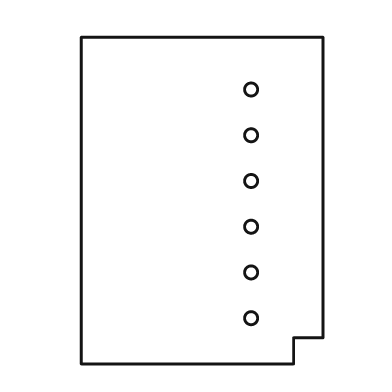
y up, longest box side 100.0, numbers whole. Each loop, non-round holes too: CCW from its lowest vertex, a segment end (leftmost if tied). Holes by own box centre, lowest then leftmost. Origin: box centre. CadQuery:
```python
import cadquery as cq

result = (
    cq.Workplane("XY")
    .moveTo(-37.0, -50.0)
    .lineTo(28.0, -50.0)
    .lineTo(28.0, -42.0)
    .lineTo(37.0, -42.0)
    .lineTo(37.0, 50.0)
    .lineTo(-37.0, 50.0)
    .close()
    .moveTo(15.0, -36.0)
    .circle(2.0)
    .moveTo(15.0, -22.0)
    .circle(2.0)
    .moveTo(15.0, -8.0)
    .circle(2.0)
    .moveTo(15.0, 6.0)
    .circle(2.0)
    .moveTo(15.0, 20.0)
    .circle(2.0)
    .moveTo(15.0, 34.0)
    .circle(2.0)
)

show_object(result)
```